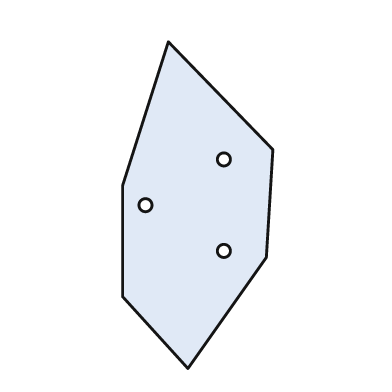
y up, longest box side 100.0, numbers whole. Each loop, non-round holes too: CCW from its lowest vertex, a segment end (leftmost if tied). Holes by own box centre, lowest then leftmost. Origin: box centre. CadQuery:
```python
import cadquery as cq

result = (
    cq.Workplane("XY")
    .moveTo(-3.0, -50.0)
    .lineTo(21.0, -16.0)
    .lineTo(23.0, 17.0)
    .lineTo(-9.0, 50.0)
    .lineTo(-23.0, 6.0)
    .lineTo(-23.0, -28.0)
    .close()
    .moveTo(8.0, -14.0)
    .circle(2.0)
    .moveTo(-16.0, 0.0)
    .circle(2.0)
    .moveTo(8.0, 14.0)
    .circle(2.0)
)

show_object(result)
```